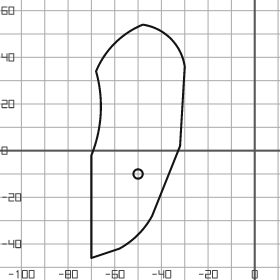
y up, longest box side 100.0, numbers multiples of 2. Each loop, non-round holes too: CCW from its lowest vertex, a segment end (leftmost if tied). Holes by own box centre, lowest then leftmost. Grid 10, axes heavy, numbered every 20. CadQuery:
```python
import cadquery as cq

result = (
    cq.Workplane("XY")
    .moveTo(-70.0, -46.0)
    .lineTo(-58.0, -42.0)
    .threePointArc((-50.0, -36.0), (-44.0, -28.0))
    .lineTo(-32.0, 2.0)
    .lineTo(-30.0, 36.0)
    .threePointArc((-36.0, 48.0), (-48.0, 54.0))
    .threePointArc((-60.0, 46.0), (-68.0, 34.0))
    .threePointArc((-66.0, 16.0), (-70.0, -2.0))
    .close()
    .moveTo(-50.0, -10.0)
    .circle(2.0)
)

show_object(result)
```